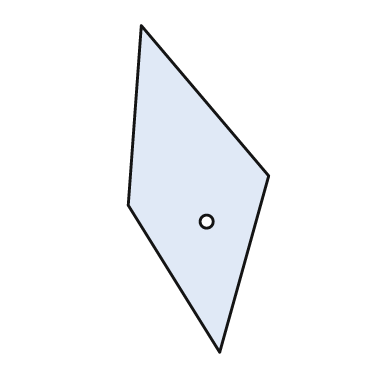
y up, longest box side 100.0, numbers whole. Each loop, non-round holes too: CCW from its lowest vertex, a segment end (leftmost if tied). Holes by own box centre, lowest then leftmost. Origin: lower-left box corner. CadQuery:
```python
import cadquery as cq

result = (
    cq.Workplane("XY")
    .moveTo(28.0, 0.0)
    .lineTo(43.0, 54.0)
    .lineTo(4.0, 100.0)
    .lineTo(0.0, 45.0)
    .close()
    .moveTo(24.0, 40.0)
    .circle(2.0)
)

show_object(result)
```